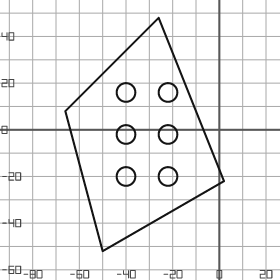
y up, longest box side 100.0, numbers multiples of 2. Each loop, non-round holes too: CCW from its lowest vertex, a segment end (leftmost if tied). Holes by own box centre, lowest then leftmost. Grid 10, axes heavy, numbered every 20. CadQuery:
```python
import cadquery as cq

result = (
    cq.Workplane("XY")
    .moveTo(-50.0, -52.0)
    .lineTo(2.0, -22.0)
    .lineTo(-26.0, 48.0)
    .lineTo(-66.0, 8.0)
    .close()
    .moveTo(-40.0, -20.0)
    .circle(4.0)
    .moveTo(-22.0, -20.0)
    .circle(4.0)
    .moveTo(-40.0, -2.0)
    .circle(4.0)
    .moveTo(-22.0, -2.0)
    .circle(4.0)
    .moveTo(-40.0, 16.0)
    .circle(4.0)
    .moveTo(-22.0, 16.0)
    .circle(4.0)
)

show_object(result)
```